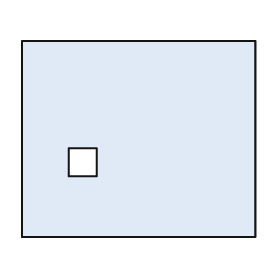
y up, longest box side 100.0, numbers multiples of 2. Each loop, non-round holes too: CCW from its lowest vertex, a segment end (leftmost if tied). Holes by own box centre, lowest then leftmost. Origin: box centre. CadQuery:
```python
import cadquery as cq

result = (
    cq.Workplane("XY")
    .moveTo(-50.0, -42.0)
    .lineTo(50.0, -42.0)
    .lineTo(50.0, 42.0)
    .lineTo(-50.0, 42.0)
    .close()
    .moveTo(-30.0, -16.0)
    .lineTo(-18.0, -16.0)
    .lineTo(-18.0, -4.0)
    .lineTo(-30.0, -4.0)
    .close()
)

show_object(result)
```